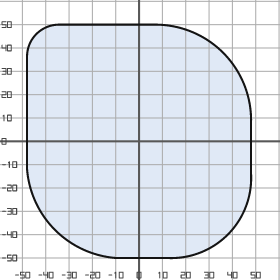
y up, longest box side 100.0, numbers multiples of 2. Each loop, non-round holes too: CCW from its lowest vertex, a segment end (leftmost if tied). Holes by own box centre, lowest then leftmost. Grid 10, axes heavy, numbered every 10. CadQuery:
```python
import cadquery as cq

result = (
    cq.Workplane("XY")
    .moveTo(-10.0, -50.0)
    .lineTo(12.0, -50.0)
    .threePointArc((38.0, -40.0), (48.0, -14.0))
    .lineTo(48.0, 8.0)
    .threePointArc((36.0, 38.0), (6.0, 50.0))
    .lineTo(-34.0, 50.0)
    .threePointArc((-44.0, 46.0), (-48.0, 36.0))
    .lineTo(-48.0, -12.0)
    .threePointArc((-36.0, -38.0), (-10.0, -50.0))
    .close()
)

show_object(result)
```